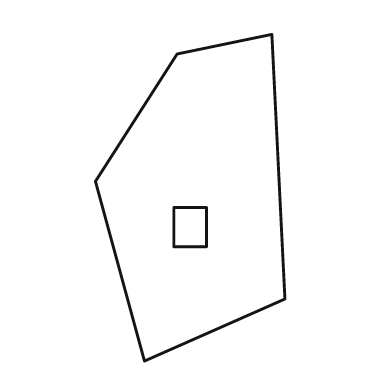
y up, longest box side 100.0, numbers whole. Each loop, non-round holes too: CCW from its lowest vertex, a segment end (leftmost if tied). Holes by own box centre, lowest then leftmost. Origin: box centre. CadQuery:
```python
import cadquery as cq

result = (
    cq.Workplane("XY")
    .moveTo(-14.0, -50.0)
    .lineTo(29.0, -31.0)
    .lineTo(25.0, 50.0)
    .lineTo(-4.0, 44.0)
    .lineTo(-29.0, 5.0)
    .close()
    .moveTo(-5.0, -15.0)
    .lineTo(5.0, -15.0)
    .lineTo(5.0, -3.0)
    .lineTo(-5.0, -3.0)
    .close()
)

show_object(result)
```